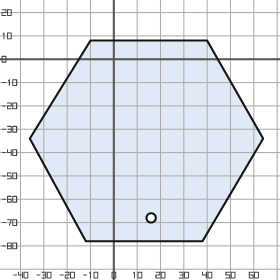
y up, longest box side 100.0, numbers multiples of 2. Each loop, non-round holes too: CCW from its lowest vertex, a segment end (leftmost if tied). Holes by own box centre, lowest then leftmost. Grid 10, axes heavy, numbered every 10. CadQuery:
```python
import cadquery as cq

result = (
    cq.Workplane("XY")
    .moveTo(-12.0, -78.0)
    .lineTo(38.0, -78.0)
    .lineTo(64.0, -34.0)
    .lineTo(40.0, 8.0)
    .lineTo(-10.0, 8.0)
    .lineTo(-36.0, -34.0)
    .close()
    .moveTo(16.0, -68.0)
    .circle(2.0)
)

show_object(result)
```